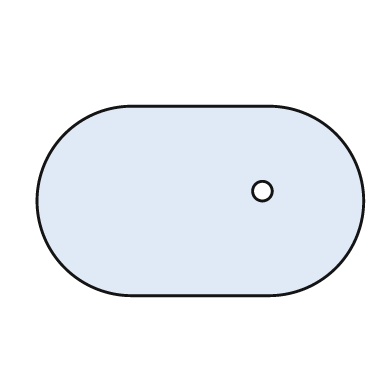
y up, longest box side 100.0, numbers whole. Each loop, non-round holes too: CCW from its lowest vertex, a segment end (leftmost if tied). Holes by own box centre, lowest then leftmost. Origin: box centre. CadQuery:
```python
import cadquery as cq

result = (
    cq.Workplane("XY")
    .moveTo(-21.0, -29.0)
    .lineTo(21.0, -29.0)
    .threePointArc((50.0, 0.0), (21.0, 29.0))
    .lineTo(-21.0, 29.0)
    .threePointArc((-50.0, 0.0), (-21.0, -29.0))
    .close()
    .moveTo(19.0, 3.0)
    .circle(3.0)
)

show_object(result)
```